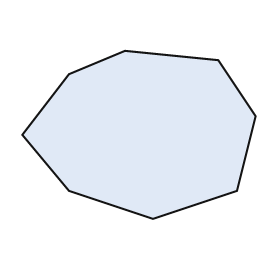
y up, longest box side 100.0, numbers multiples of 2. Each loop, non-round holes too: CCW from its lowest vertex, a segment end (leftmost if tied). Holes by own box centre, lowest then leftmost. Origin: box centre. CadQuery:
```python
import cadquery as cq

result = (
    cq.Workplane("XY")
    .moveTo(6.0, -36.0)
    .lineTo(42.0, -24.0)
    .lineTo(50.0, 8.0)
    .lineTo(34.0, 32.0)
    .lineTo(-6.0, 36.0)
    .lineTo(-30.0, 26.0)
    .lineTo(-50.0, 0.0)
    .lineTo(-30.0, -24.0)
    .close()
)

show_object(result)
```